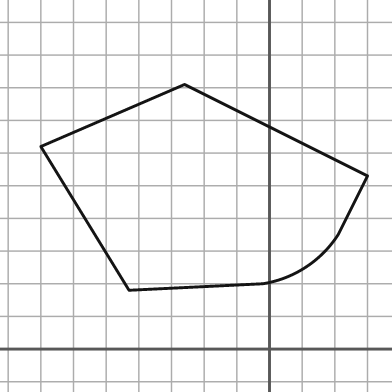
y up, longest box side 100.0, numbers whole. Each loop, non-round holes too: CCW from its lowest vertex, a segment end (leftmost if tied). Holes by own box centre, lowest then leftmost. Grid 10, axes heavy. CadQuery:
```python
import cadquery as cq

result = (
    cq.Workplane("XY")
    .moveTo(-43.0, 18.0)
    .lineTo(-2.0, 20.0)
    .threePointArc((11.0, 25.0), (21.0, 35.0))
    .lineTo(30.0, 53.0)
    .lineTo(-26.0, 81.0)
    .lineTo(-70.0, 62.0)
    .close()
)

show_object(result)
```